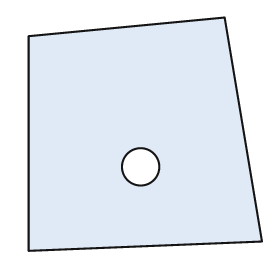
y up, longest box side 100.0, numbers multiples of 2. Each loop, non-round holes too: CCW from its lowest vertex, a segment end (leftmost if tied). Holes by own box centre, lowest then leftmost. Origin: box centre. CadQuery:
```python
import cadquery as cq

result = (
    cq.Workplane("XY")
    .moveTo(-50.0, -50.0)
    .lineTo(50.0, -46.0)
    .lineTo(34.0, 50.0)
    .lineTo(-50.0, 42.0)
    .close()
    .moveTo(-2.0, -14.0)
    .circle(8.0)
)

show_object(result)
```